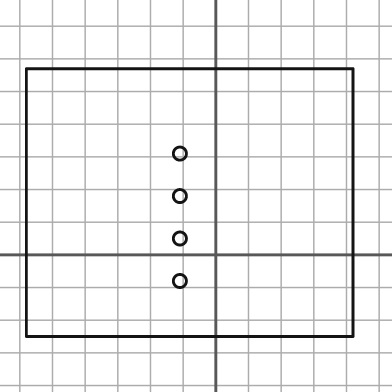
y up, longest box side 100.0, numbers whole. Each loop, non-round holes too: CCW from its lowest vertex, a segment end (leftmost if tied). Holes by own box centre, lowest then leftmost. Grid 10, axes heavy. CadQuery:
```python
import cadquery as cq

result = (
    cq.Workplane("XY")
    .moveTo(-58.0, -25.0)
    .lineTo(42.0, -25.0)
    .lineTo(42.0, 57.0)
    .lineTo(-58.0, 57.0)
    .close()
    .moveTo(-11.0, -8.0)
    .circle(2.0)
    .moveTo(-11.0, 5.0)
    .circle(2.0)
    .moveTo(-11.0, 18.0)
    .circle(2.0)
    .moveTo(-11.0, 31.0)
    .circle(2.0)
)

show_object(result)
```